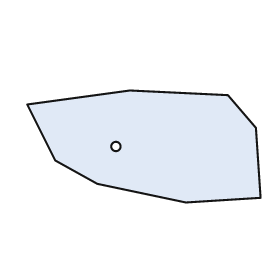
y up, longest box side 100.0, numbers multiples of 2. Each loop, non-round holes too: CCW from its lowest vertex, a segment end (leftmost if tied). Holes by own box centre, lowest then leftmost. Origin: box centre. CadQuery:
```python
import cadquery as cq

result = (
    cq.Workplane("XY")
    .moveTo(18.0, -24.0)
    .lineTo(50.0, -22.0)
    .lineTo(48.0, 8.0)
    .lineTo(36.0, 22.0)
    .lineTo(-6.0, 24.0)
    .lineTo(-50.0, 18.0)
    .lineTo(-38.0, -6.0)
    .lineTo(-20.0, -16.0)
    .close()
    .moveTo(-12.0, 0.0)
    .circle(2.0)
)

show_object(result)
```